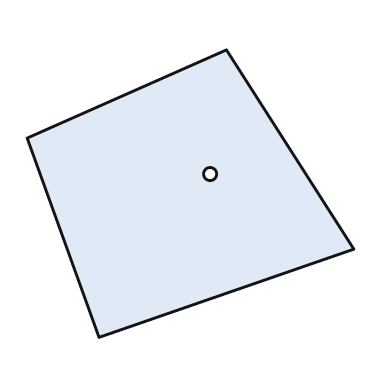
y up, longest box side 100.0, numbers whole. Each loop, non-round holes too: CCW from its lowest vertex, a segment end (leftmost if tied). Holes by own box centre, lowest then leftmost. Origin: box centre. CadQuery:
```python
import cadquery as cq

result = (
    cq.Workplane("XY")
    .moveTo(-28.0, -44.0)
    .lineTo(50.0, -17.0)
    .lineTo(11.0, 44.0)
    .lineTo(-50.0, 17.0)
    .close()
    .moveTo(6.0, 6.0)
    .circle(2.0)
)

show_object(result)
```